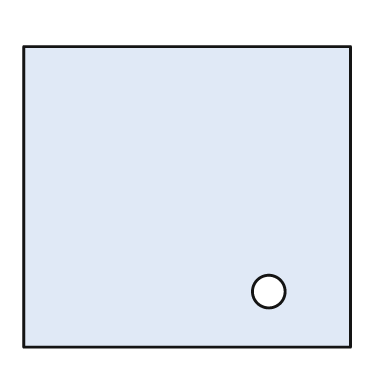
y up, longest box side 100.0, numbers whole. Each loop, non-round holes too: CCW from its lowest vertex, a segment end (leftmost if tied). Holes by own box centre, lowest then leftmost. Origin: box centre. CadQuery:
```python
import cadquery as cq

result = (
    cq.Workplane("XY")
    .moveTo(-50.0, -46.0)
    .lineTo(50.0, -46.0)
    .lineTo(50.0, 46.0)
    .lineTo(-50.0, 46.0)
    .close()
    .moveTo(25.0, -29.0)
    .circle(5.0)
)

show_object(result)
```